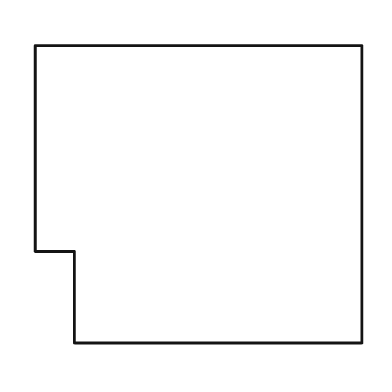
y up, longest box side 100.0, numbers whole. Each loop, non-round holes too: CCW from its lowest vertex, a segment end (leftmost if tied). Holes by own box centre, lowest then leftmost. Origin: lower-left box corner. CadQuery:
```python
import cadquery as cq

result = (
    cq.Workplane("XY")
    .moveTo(12.0, 0.0)
    .lineTo(100.0, 0.0)
    .lineTo(100.0, 91.0)
    .lineTo(0.0, 91.0)
    .lineTo(0.0, 28.0)
    .lineTo(12.0, 28.0)
    .close()
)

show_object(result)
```